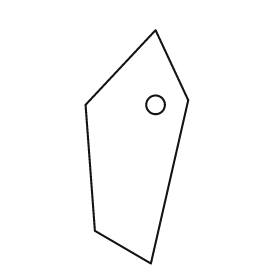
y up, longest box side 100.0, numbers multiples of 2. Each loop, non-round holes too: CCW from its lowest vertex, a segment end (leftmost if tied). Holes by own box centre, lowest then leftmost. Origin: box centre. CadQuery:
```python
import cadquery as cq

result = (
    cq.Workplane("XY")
    .moveTo(6.0, -50.0)
    .lineTo(22.0, 20.0)
    .lineTo(8.0, 50.0)
    .lineTo(-22.0, 18.0)
    .lineTo(-18.0, -36.0)
    .close()
    .moveTo(8.0, 18.0)
    .circle(4.0)
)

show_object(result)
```